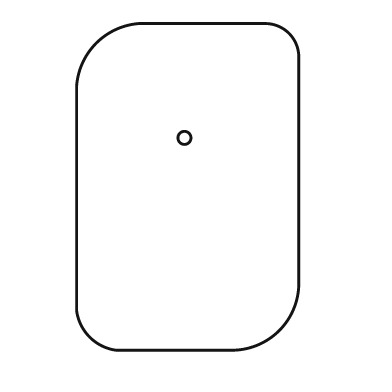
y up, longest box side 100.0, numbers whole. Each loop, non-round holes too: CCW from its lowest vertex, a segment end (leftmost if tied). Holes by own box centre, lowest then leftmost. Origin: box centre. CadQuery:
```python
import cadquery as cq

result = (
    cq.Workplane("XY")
    .moveTo(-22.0, -50.0)
    .lineTo(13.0, -50.0)
    .threePointArc((28.0, -44.0), (34.0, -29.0))
    .lineTo(34.0, 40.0)
    .threePointArc((31.0, 47.0), (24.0, 50.0))
    .lineTo(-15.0, 50.0)
    .threePointArc((-28.0, 44.0), (-34.0, 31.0))
    .lineTo(-34.0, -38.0)
    .threePointArc((-30.0, -46.0), (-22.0, -50.0))
    .close()
    .moveTo(-1.0, 15.0)
    .circle(2.0)
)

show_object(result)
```